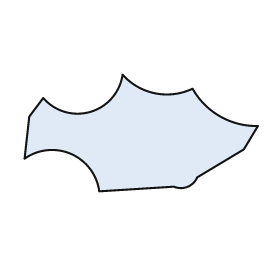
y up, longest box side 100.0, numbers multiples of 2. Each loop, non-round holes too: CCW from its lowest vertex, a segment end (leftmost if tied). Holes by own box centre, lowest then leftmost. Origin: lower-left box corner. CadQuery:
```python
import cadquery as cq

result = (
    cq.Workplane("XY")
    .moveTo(32.0, 0.0)
    .lineTo(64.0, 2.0)
    .threePointArc((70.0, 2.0), (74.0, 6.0))
    .lineTo(94.0, 18.0)
    .lineTo(100.0, 28.0)
    .threePointArc((84.0, 32.0), (72.0, 44.0))
    .threePointArc((56.0, 42.0), (42.0, 50.0))
    .threePointArc((28.0, 34.0), (8.0, 40.0))
    .lineTo(2.0, 32.0)
    .lineTo(0.0, 14.0)
    .threePointArc((20.0, 16.0), (32.0, 0.0))
    .close()
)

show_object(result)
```